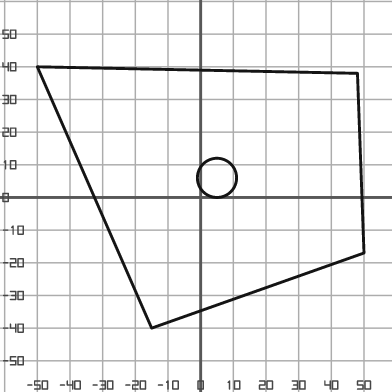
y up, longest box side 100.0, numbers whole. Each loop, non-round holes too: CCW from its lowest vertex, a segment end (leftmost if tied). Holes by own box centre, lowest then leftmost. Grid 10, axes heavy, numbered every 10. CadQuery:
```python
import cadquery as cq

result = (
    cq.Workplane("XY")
    .moveTo(-15.0, -40.0)
    .lineTo(50.0, -17.0)
    .lineTo(48.0, 38.0)
    .lineTo(-50.0, 40.0)
    .close()
    .moveTo(5.0, 6.0)
    .circle(6.0)
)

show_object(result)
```